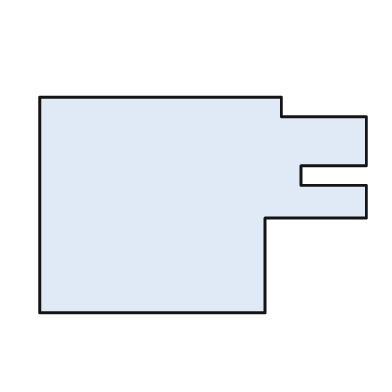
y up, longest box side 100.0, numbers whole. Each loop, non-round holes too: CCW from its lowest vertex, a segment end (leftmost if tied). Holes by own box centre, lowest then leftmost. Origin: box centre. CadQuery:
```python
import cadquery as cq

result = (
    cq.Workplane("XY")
    .moveTo(-50.0, -33.0)
    .lineTo(19.0, -33.0)
    .lineTo(19.0, -4.0)
    .lineTo(50.0, -4.0)
    .lineTo(50.0, 6.0)
    .lineTo(30.0, 6.0)
    .lineTo(30.0, 12.0)
    .lineTo(50.0, 12.0)
    .lineTo(50.0, 27.0)
    .lineTo(24.0, 27.0)
    .lineTo(24.0, 33.0)
    .lineTo(-50.0, 33.0)
    .close()
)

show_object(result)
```